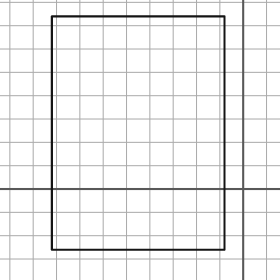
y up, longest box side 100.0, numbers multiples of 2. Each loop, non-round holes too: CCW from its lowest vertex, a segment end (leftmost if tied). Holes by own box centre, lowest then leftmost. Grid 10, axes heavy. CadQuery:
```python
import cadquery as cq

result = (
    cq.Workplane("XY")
    .moveTo(-82.0, -26.0)
    .lineTo(-8.0, -26.0)
    .lineTo(-8.0, 74.0)
    .lineTo(-82.0, 74.0)
    .close()
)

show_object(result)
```